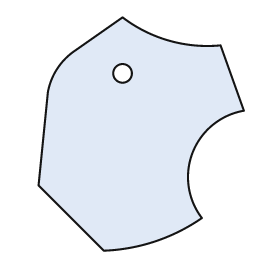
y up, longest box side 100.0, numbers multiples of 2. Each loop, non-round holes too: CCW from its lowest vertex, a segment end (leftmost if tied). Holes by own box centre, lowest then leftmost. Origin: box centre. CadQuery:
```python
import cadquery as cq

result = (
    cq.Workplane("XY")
    .moveTo(-16.0, -50.0)
    .threePointArc((6.0, -46.0), (26.0, -36.0))
    .threePointArc((22.0, -8.0), (44.0, 10.0))
    .lineTo(34.0, 38.0)
    .threePointArc((12.0, 40.0), (-8.0, 50.0))
    .lineTo(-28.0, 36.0)
    .threePointArc((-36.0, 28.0), (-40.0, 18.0))
    .lineTo(-44.0, -22.0)
    .close()
    .moveTo(-8.0, 26.0)
    .circle(4.0)
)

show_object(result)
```